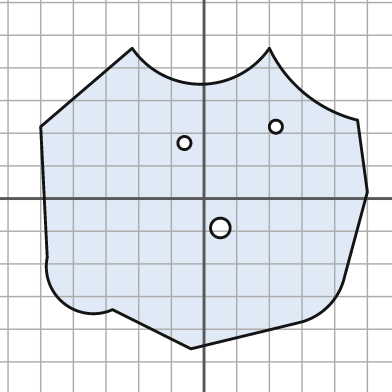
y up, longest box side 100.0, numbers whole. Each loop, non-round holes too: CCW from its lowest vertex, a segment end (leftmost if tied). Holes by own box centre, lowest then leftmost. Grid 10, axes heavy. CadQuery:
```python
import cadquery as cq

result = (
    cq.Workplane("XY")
    .moveTo(-4.0, -46.0)
    .lineTo(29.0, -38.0)
    .threePointArc((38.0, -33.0), (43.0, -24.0))
    .lineTo(50.0, 2.0)
    .lineTo(47.0, 24.0)
    .threePointArc((31.0, 32.0), (20.0, 46.0))
    .threePointArc((-1.0, 35.0), (-22.0, 46.0))
    .lineTo(-50.0, 22.0)
    .lineTo(-48.0, -18.0)
    .threePointArc((-43.0, -32.0), (-28.0, -34.0))
    .close()
    .moveTo(5.0, -9.0)
    .circle(3.0)
    .moveTo(-6.0, 17.0)
    .circle(2.0)
    .moveTo(22.0, 22.0)
    .circle(2.0)
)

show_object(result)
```